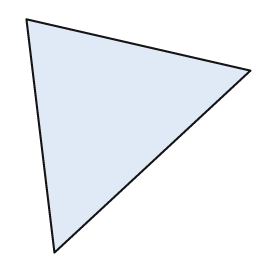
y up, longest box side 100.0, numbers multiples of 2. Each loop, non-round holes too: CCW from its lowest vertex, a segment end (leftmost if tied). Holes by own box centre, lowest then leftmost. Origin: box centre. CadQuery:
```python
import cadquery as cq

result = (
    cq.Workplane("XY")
    .moveTo(-36.0, -50.0)
    .lineTo(48.0, 28.0)
    .lineTo(-48.0, 50.0)
    .close()
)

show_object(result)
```